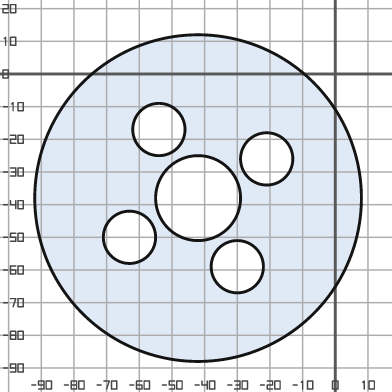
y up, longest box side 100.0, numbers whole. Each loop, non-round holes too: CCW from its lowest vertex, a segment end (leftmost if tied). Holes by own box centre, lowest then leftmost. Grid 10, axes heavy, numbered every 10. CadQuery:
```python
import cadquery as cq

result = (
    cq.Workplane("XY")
    .moveTo(-42.0, -38.0)
    .circle(50.0)
    .moveTo(-30.0, -59.0)
    .circle(8.0)
    .moveTo(-63.0, -50.0)
    .circle(8.0)
    .moveTo(-42.0, -38.0)
    .circle(13.0)
    .moveTo(-21.0, -26.0)
    .circle(8.0)
    .moveTo(-54.0, -17.0)
    .circle(8.0)
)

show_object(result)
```